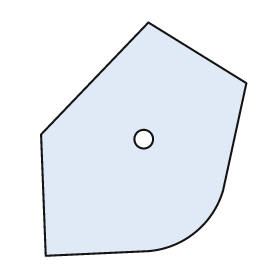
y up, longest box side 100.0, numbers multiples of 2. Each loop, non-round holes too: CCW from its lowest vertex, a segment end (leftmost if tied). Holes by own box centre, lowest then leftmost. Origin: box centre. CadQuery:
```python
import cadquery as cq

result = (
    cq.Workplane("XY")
    .moveTo(-42.0, -50.0)
    .lineTo(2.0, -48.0)
    .threePointArc((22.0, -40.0), (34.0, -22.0))
    .lineTo(44.0, 24.0)
    .lineTo(2.0, 50.0)
    .lineTo(-44.0, 2.0)
    .close()
    .moveTo(0.0, 0.0)
    .circle(4.0)
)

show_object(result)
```